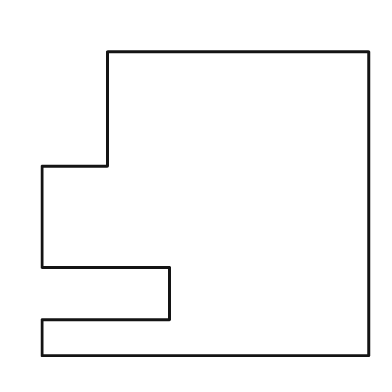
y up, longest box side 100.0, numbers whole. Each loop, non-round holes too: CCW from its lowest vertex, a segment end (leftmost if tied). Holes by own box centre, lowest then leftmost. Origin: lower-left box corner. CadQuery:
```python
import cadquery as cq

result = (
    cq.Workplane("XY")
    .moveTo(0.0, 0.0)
    .lineTo(100.0, 0.0)
    .lineTo(100.0, 93.0)
    .lineTo(20.0, 93.0)
    .lineTo(20.0, 58.0)
    .lineTo(0.0, 58.0)
    .lineTo(0.0, 27.0)
    .lineTo(39.0, 27.0)
    .lineTo(39.0, 11.0)
    .lineTo(0.0, 11.0)
    .close()
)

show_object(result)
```